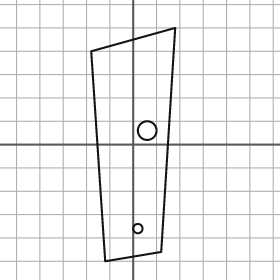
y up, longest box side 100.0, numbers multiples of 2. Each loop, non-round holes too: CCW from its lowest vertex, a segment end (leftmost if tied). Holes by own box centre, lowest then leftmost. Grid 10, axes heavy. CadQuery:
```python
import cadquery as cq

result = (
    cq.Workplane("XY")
    .moveTo(-12.0, -50.0)
    .lineTo(12.0, -46.0)
    .lineTo(18.0, 50.0)
    .lineTo(-18.0, 40.0)
    .close()
    .moveTo(2.0, -36.0)
    .circle(2.0)
    .moveTo(6.0, 6.0)
    .circle(4.0)
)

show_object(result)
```